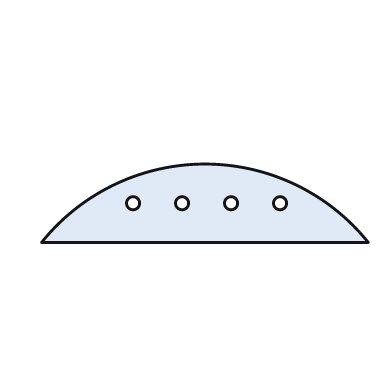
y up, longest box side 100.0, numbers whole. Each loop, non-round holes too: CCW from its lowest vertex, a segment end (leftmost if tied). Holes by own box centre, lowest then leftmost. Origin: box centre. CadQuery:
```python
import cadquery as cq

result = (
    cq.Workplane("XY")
    .moveTo(-50.0, -12.0)
    .lineTo(50.0, -12.0)
    .threePointArc((0.0, 12.0), (-50.0, -12.0))
    .close()
    .moveTo(-22.0, 0.0)
    .circle(2.0)
    .moveTo(-7.0, 0.0)
    .circle(2.0)
    .moveTo(8.0, 0.0)
    .circle(2.0)
    .moveTo(23.0, 0.0)
    .circle(2.0)
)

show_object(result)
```